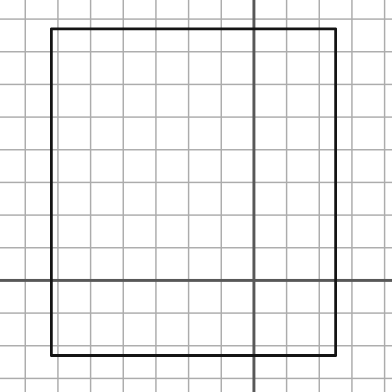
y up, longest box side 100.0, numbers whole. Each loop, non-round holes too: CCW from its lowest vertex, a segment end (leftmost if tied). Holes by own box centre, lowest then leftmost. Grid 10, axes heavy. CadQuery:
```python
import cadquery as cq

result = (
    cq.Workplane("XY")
    .moveTo(-62.0, -23.0)
    .lineTo(25.0, -23.0)
    .lineTo(25.0, 77.0)
    .lineTo(-62.0, 77.0)
    .close()
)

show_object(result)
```